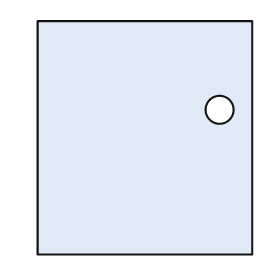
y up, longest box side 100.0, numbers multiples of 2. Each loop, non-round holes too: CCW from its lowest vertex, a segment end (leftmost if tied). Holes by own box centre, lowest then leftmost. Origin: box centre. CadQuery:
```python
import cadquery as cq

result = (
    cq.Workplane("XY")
    .moveTo(-46.0, -50.0)
    .lineTo(46.0, -50.0)
    .lineTo(46.0, 50.0)
    .lineTo(-46.0, 50.0)
    .close()
    .moveTo(32.0, 12.0)
    .circle(6.0)
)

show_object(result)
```